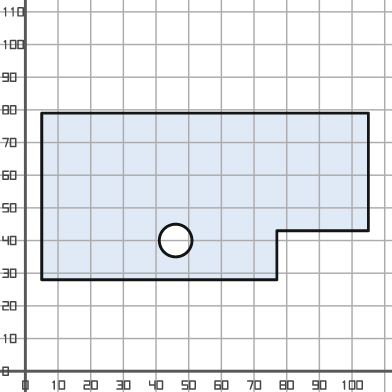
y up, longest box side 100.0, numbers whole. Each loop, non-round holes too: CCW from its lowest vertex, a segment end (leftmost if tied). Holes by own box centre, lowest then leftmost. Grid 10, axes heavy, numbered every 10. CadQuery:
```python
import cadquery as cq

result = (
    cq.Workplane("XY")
    .moveTo(5.0, 28.0)
    .lineTo(77.0, 28.0)
    .lineTo(77.0, 43.0)
    .lineTo(105.0, 43.0)
    .lineTo(105.0, 79.0)
    .lineTo(5.0, 79.0)
    .close()
    .moveTo(46.0, 40.0)
    .circle(5.0)
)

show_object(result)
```